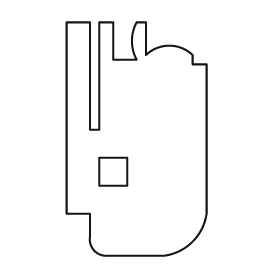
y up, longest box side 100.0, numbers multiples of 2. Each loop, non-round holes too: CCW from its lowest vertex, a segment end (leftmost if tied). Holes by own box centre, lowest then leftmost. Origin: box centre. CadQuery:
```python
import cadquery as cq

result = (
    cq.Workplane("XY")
    .moveTo(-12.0, -50.0)
    .lineTo(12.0, -50.0)
    .threePointArc((24.0, -44.0), (30.0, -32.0))
    .lineTo(30.0, 32.0)
    .lineTo(24.0, 32.0)
    .lineTo(24.0, 36.0)
    .threePointArc((14.0, 40.0), (4.0, 36.0))
    .lineTo(4.0, 50.0)
    .lineTo(0.0, 50.0)
    .threePointArc((-2.0, 42.0), (0.0, 34.0))
    .lineTo(-10.0, 34.0)
    .lineTo(-10.0, 50.0)
    .lineTo(-16.0, 50.0)
    .lineTo(-16.0, 4.0)
    .lineTo(-20.0, 4.0)
    .lineTo(-20.0, 50.0)
    .lineTo(-30.0, 50.0)
    .lineTo(-30.0, -32.0)
    .lineTo(-20.0, -32.0)
    .lineTo(-20.0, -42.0)
    .threePointArc((-18.0, -48.0), (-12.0, -50.0))
    .close()
    .moveTo(-16.0, -20.0)
    .lineTo(-4.0, -20.0)
    .lineTo(-4.0, -8.0)
    .lineTo(-16.0, -8.0)
    .close()
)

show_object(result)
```